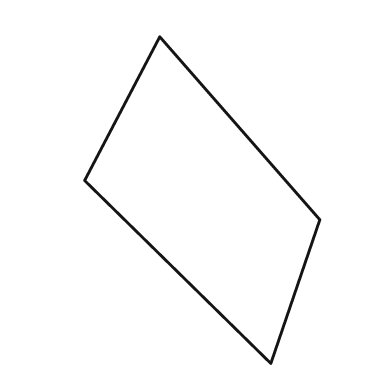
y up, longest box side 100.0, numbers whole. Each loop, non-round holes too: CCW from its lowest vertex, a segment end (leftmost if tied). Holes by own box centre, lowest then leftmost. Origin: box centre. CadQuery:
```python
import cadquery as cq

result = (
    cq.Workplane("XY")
    .moveTo(21.0, -50.0)
    .lineTo(36.0, -6.0)
    .lineTo(-13.0, 50.0)
    .lineTo(-36.0, 6.0)
    .close()
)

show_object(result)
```